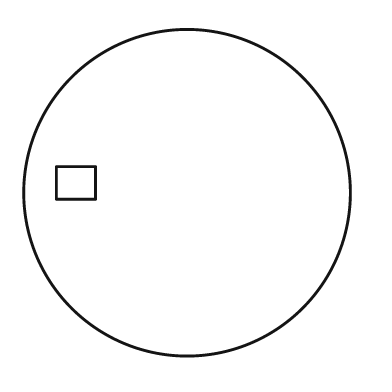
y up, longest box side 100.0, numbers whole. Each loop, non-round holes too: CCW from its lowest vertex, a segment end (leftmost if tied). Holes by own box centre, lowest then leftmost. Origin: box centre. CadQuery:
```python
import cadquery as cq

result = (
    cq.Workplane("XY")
    .moveTo(0.0, 0.0)
    .circle(50.0)
    .moveTo(-40.0, -2.0)
    .lineTo(-28.0, -2.0)
    .lineTo(-28.0, 8.0)
    .lineTo(-40.0, 8.0)
    .close()
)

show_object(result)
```